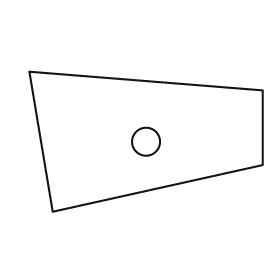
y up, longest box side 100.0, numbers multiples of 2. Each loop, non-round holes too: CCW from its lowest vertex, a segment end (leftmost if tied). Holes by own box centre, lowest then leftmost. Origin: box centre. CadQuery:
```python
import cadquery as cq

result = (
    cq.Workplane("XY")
    .moveTo(-40.0, -30.0)
    .lineTo(50.0, -10.0)
    .lineTo(50.0, 22.0)
    .lineTo(-50.0, 30.0)
    .close()
    .moveTo(0.0, 0.0)
    .circle(6.0)
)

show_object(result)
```